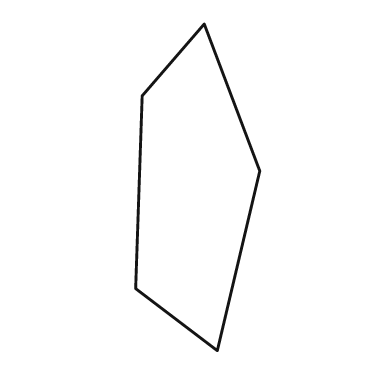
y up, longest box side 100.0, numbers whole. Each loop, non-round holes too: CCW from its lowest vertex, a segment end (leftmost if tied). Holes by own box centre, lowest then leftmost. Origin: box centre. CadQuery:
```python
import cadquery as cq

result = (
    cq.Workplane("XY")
    .moveTo(6.0, -50.0)
    .lineTo(19.0, 5.0)
    .lineTo(2.0, 50.0)
    .lineTo(-17.0, 28.0)
    .lineTo(-19.0, -31.0)
    .close()
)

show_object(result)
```